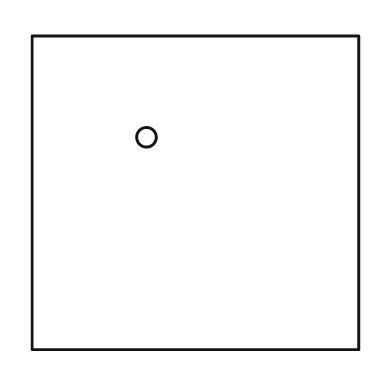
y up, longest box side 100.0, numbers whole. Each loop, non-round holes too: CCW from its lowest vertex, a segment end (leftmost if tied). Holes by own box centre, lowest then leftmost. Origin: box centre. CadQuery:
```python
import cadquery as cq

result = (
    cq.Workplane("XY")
    .moveTo(-50.0, -48.0)
    .lineTo(50.0, -48.0)
    .lineTo(50.0, 48.0)
    .lineTo(-50.0, 48.0)
    .close()
    .moveTo(-15.0, 17.0)
    .circle(3.0)
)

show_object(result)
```